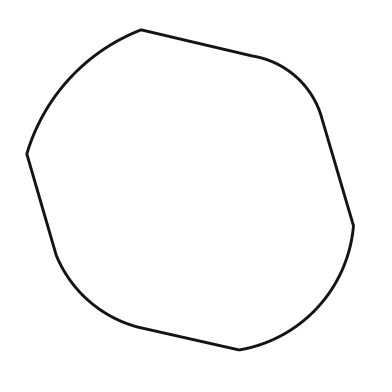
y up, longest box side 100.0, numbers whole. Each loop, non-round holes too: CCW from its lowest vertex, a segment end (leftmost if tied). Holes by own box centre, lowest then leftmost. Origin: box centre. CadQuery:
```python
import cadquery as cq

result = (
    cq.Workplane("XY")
    .moveTo(15.0, -49.0)
    .threePointArc((39.0, -36.0), (50.0, -11.0))
    .lineTo(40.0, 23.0)
    .threePointArc((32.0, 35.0), (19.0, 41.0))
    .lineTo(-15.0, 49.0)
    .threePointArc((-37.0, 34.0), (-50.0, 11.0))
    .lineTo(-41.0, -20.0)
    .threePointArc((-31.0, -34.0), (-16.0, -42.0))
    .close()
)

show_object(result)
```